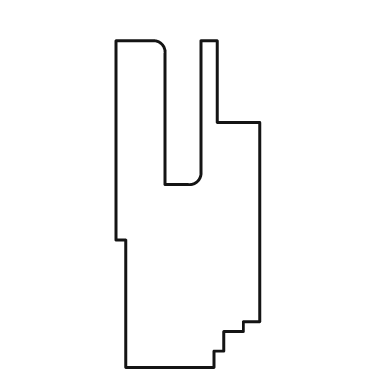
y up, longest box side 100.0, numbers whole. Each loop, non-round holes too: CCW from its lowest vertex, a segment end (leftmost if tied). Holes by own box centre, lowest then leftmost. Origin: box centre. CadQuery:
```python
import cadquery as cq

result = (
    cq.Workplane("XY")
    .moveTo(-19.0, -50.0)
    .lineTo(8.0, -50.0)
    .lineTo(8.0, -45.0)
    .lineTo(11.0, -45.0)
    .lineTo(11.0, -39.0)
    .lineTo(17.0, -39.0)
    .lineTo(17.0, -36.0)
    .lineTo(22.0, -36.0)
    .lineTo(22.0, 25.0)
    .lineTo(9.0, 25.0)
    .lineTo(9.0, 50.0)
    .lineTo(4.0, 50.0)
    .lineTo(4.0, 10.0)
    .threePointArc((3.0, 7.0), (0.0, 6.0))
    .lineTo(-7.0, 6.0)
    .lineTo(-7.0, 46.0)
    .threePointArc((-8.0, 49.0), (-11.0, 50.0))
    .lineTo(-22.0, 50.0)
    .lineTo(-22.0, -11.0)
    .lineTo(-19.0, -11.0)
    .close()
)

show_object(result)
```